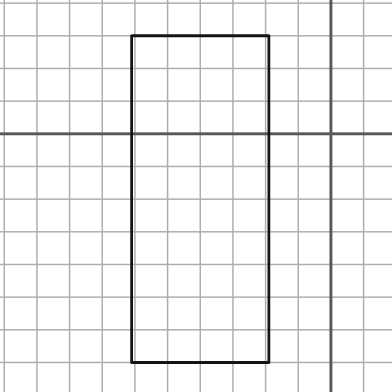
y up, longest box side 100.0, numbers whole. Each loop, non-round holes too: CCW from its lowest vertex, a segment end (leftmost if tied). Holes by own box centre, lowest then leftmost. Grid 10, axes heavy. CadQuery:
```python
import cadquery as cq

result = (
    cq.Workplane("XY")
    .moveTo(-61.0, -70.0)
    .lineTo(-19.0, -70.0)
    .lineTo(-19.0, 30.0)
    .lineTo(-61.0, 30.0)
    .close()
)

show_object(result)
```